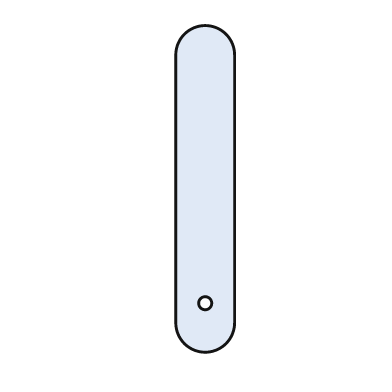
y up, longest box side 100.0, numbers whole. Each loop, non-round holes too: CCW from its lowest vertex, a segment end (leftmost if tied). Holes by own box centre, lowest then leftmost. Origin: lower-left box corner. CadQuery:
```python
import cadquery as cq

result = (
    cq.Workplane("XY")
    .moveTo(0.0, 9.0)
    .threePointArc((9.0, 0.0), (18.0, 9.0))
    .lineTo(18.0, 91.0)
    .threePointArc((9.0, 100.0), (0.0, 91.0))
    .close()
    .moveTo(9.0, 15.0)
    .circle(2.0)
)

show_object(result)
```